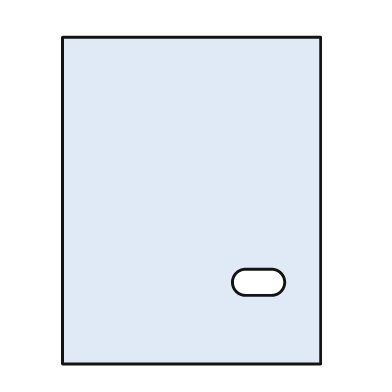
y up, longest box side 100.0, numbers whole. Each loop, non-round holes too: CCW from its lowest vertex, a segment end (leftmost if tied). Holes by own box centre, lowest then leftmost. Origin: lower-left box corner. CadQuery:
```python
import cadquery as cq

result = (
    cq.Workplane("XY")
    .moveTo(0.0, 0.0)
    .lineTo(79.0, 0.0)
    .lineTo(79.0, 100.0)
    .lineTo(0.0, 100.0)
    .close()
    .moveTo(56.0, 21.0)
    .lineTo(64.0, 21.0)
    .threePointArc((68.0, 25.0), (64.0, 29.0))
    .lineTo(56.0, 29.0)
    .threePointArc((52.0, 25.0), (56.0, 21.0))
    .close()
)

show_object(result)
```